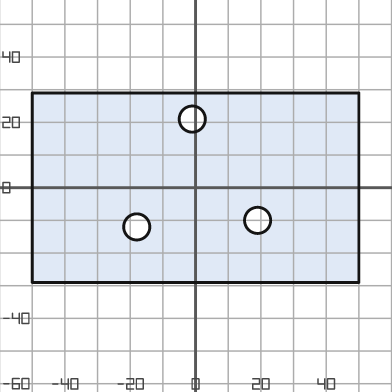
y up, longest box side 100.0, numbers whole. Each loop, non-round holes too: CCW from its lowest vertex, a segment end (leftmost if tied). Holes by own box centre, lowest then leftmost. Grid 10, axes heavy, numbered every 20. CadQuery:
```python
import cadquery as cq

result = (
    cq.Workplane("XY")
    .moveTo(-50.0, -29.0)
    .lineTo(50.0, -29.0)
    .lineTo(50.0, 29.0)
    .lineTo(-50.0, 29.0)
    .close()
    .moveTo(-18.0, -12.0)
    .circle(4.0)
    .moveTo(19.0, -10.0)
    .circle(4.0)
    .moveTo(-1.0, 21.0)
    .circle(4.0)
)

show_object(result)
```